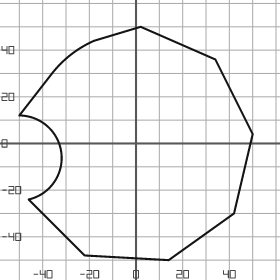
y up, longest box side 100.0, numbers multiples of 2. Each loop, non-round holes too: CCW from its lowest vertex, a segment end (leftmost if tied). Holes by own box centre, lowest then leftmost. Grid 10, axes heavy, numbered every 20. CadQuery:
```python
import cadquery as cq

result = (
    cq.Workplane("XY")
    .moveTo(14.0, -50.0)
    .lineTo(42.0, -30.0)
    .lineTo(50.0, 4.0)
    .lineTo(34.0, 36.0)
    .lineTo(2.0, 50.0)
    .lineTo(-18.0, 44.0)
    .threePointArc((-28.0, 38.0), (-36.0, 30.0))
    .lineTo(-50.0, 12.0)
    .threePointArc((-32.0, -4.0), (-46.0, -24.0))
    .lineTo(-22.0, -48.0)
    .close()
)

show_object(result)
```